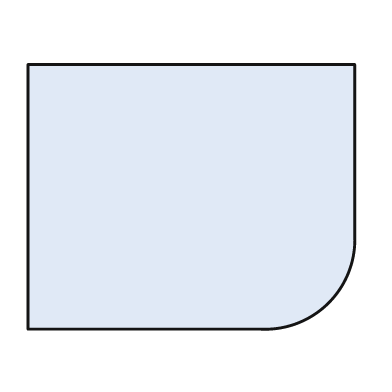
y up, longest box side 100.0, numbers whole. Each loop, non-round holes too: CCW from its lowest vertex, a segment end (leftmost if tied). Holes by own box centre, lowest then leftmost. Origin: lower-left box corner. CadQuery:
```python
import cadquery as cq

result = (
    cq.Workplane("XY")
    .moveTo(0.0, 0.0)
    .lineTo(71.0, 0.0)
    .threePointArc((92.0, 8.0), (100.0, 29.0))
    .lineTo(100.0, 81.0)
    .lineTo(0.0, 81.0)
    .close()
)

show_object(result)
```